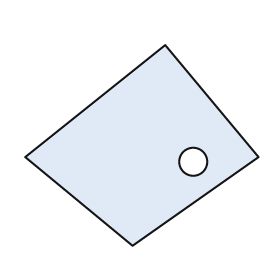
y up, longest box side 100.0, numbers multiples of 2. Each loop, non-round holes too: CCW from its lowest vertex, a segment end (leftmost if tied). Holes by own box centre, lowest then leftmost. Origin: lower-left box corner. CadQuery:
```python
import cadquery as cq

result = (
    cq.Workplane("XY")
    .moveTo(46.0, 0.0)
    .lineTo(100.0, 38.0)
    .lineTo(60.0, 86.0)
    .lineTo(0.0, 38.0)
    .close()
    .moveTo(72.0, 36.0)
    .circle(6.0)
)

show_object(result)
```